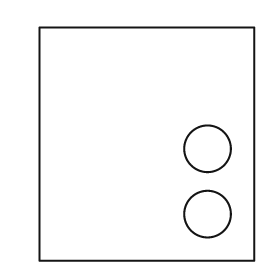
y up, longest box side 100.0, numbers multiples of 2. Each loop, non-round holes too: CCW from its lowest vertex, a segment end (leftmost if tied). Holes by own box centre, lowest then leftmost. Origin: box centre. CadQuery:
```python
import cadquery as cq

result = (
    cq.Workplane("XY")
    .moveTo(-46.0, -50.0)
    .lineTo(46.0, -50.0)
    .lineTo(46.0, 50.0)
    .lineTo(-46.0, 50.0)
    .close()
    .moveTo(26.0, -30.0)
    .circle(10.0)
    .moveTo(26.0, -2.0)
    .circle(10.0)
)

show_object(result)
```